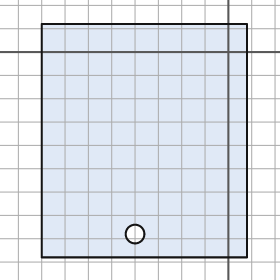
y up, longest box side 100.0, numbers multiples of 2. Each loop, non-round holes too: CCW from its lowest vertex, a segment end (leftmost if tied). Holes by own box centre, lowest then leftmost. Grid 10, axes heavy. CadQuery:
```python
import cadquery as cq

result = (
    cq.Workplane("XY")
    .moveTo(-80.0, -88.0)
    .lineTo(8.0, -88.0)
    .lineTo(8.0, 12.0)
    .lineTo(-80.0, 12.0)
    .close()
    .moveTo(-40.0, -78.0)
    .circle(4.0)
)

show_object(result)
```